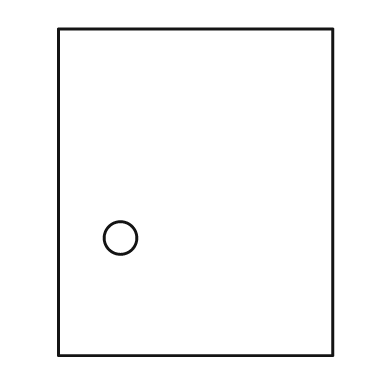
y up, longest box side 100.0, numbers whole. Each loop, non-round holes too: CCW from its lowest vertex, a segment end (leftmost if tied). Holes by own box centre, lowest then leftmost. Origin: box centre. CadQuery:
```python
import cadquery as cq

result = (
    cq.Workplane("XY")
    .moveTo(-42.0, -50.0)
    .lineTo(42.0, -50.0)
    .lineTo(42.0, 50.0)
    .lineTo(-42.0, 50.0)
    .close()
    .moveTo(-23.0, -14.0)
    .circle(5.0)
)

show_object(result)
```